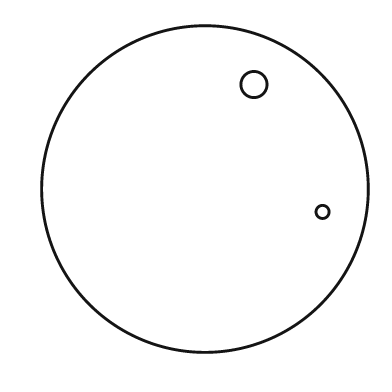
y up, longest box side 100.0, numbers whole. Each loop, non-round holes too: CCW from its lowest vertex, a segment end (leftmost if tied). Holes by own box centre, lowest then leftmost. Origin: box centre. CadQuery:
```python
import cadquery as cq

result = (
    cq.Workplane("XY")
    .moveTo(0.0, 0.0)
    .circle(50.0)
    .moveTo(36.0, -7.0)
    .circle(2.0)
    .moveTo(15.0, 32.0)
    .circle(4.0)
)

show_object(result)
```